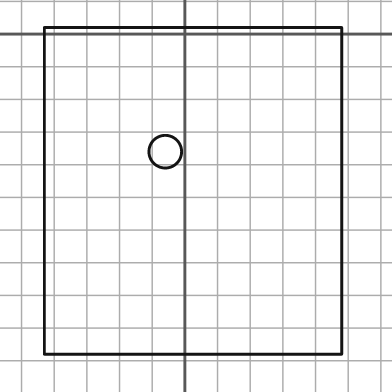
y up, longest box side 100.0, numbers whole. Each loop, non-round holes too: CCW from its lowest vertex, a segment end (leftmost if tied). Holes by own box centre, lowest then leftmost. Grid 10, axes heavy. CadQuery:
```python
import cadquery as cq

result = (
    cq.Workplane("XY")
    .moveTo(-43.0, -98.0)
    .lineTo(48.0, -98.0)
    .lineTo(48.0, 2.0)
    .lineTo(-43.0, 2.0)
    .close()
    .moveTo(-6.0, -36.0)
    .circle(5.0)
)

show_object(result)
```